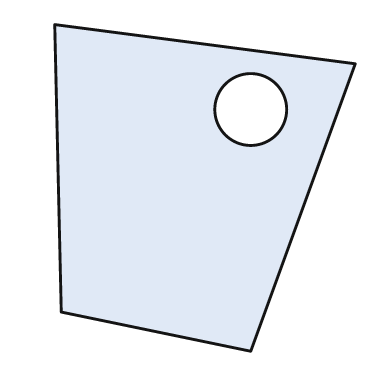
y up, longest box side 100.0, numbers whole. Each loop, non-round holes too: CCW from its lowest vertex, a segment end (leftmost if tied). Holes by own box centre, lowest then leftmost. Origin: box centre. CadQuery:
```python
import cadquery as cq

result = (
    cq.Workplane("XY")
    .moveTo(14.0, -50.0)
    .lineTo(46.0, 38.0)
    .lineTo(-46.0, 50.0)
    .lineTo(-44.0, -38.0)
    .close()
    .moveTo(14.0, 24.0)
    .circle(11.0)
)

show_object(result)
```